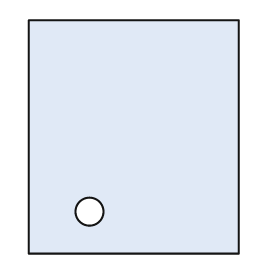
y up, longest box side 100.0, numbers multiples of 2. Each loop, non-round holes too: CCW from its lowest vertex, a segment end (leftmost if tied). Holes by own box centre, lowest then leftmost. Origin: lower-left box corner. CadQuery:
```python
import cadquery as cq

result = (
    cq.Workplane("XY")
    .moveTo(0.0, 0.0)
    .lineTo(90.0, 0.0)
    .lineTo(90.0, 100.0)
    .lineTo(0.0, 100.0)
    .close()
    .moveTo(26.0, 18.0)
    .circle(6.0)
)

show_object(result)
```